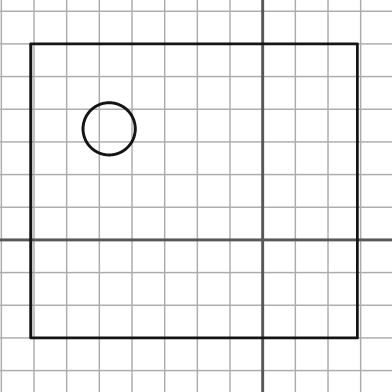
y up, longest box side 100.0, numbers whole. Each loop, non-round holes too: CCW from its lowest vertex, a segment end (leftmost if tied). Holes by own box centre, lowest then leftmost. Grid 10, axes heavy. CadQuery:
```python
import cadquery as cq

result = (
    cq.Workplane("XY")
    .moveTo(-71.0, -30.0)
    .lineTo(29.0, -30.0)
    .lineTo(29.0, 60.0)
    .lineTo(-71.0, 60.0)
    .close()
    .moveTo(-47.0, 34.0)
    .circle(8.0)
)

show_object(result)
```